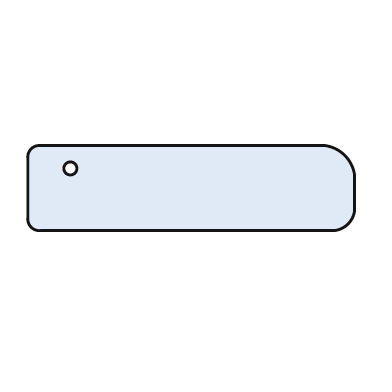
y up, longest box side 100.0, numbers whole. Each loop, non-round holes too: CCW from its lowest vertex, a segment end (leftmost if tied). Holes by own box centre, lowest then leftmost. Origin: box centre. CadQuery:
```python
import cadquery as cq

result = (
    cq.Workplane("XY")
    .moveTo(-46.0, -13.0)
    .lineTo(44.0, -13.0)
    .threePointArc((48.0, -11.0), (50.0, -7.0))
    .lineTo(50.0, 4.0)
    .threePointArc((47.0, 10.0), (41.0, 13.0))
    .lineTo(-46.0, 13.0)
    .threePointArc((-49.0, 12.0), (-50.0, 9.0))
    .lineTo(-50.0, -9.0)
    .threePointArc((-49.0, -12.0), (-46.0, -13.0))
    .close()
    .moveTo(-37.0, 6.0)
    .circle(2.0)
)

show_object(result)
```